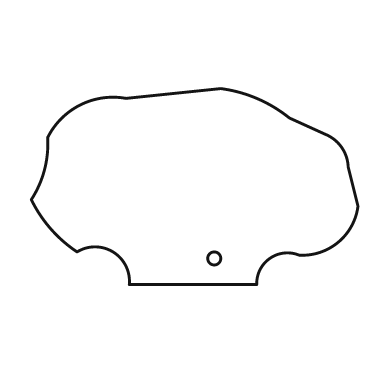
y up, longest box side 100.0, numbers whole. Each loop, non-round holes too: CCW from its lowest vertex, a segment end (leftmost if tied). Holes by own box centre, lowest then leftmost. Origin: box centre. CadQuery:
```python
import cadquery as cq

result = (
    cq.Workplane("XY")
    .moveTo(-20.0, -30.0)
    .lineTo(19.0, -30.0)
    .threePointArc((23.0, -22.0), (32.0, -21.0))
    .threePointArc((44.0, -17.0), (50.0, -6.0))
    .lineTo(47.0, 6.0)
    .threePointArc((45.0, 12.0), (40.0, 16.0))
    .lineTo(29.0, 21.0)
    .threePointArc((19.0, 27.0), (8.0, 30.0))
    .lineTo(-21.0, 27.0)
    .threePointArc((-35.0, 25.0), (-45.0, 15.0))
    .threePointArc((-46.0, 5.0), (-50.0, -4.0))
    .threePointArc((-44.0, -13.0), (-36.0, -20.0))
    .threePointArc((-25.0, -20.0), (-20.0, -30.0))
    .close()
    .moveTo(6.0, -22.0)
    .circle(2.0)
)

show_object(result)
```